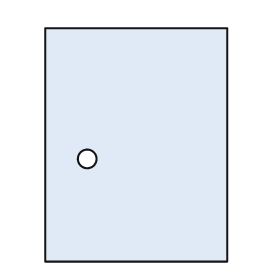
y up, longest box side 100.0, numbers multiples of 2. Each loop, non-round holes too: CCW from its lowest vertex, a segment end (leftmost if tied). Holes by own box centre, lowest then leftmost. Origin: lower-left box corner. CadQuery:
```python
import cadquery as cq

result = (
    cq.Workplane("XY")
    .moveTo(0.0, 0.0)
    .lineTo(78.0, 0.0)
    .lineTo(78.0, 100.0)
    .lineTo(0.0, 100.0)
    .close()
    .moveTo(18.0, 44.0)
    .circle(4.0)
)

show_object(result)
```